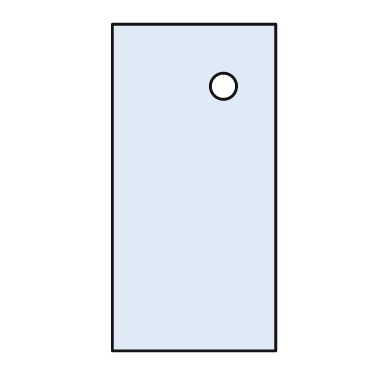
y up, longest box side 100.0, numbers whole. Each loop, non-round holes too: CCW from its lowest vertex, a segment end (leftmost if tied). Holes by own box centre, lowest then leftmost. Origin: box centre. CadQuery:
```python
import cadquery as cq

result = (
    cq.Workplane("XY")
    .moveTo(-25.0, -50.0)
    .lineTo(25.0, -50.0)
    .lineTo(25.0, 50.0)
    .lineTo(-25.0, 50.0)
    .close()
    .moveTo(9.0, 31.0)
    .circle(4.0)
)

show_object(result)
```